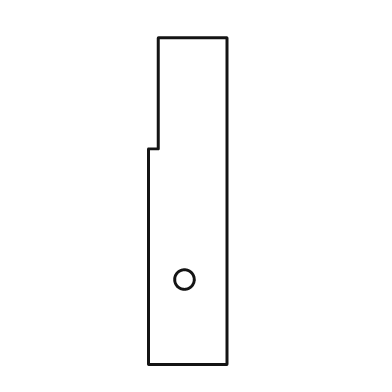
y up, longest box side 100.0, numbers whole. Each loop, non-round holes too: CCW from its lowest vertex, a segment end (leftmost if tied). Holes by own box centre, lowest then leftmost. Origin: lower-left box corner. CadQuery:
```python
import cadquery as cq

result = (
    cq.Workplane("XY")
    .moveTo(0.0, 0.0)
    .lineTo(24.0, 0.0)
    .lineTo(24.0, 100.0)
    .lineTo(3.0, 100.0)
    .lineTo(3.0, 66.0)
    .lineTo(0.0, 66.0)
    .close()
    .moveTo(11.0, 26.0)
    .circle(3.0)
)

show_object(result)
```